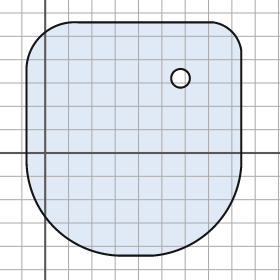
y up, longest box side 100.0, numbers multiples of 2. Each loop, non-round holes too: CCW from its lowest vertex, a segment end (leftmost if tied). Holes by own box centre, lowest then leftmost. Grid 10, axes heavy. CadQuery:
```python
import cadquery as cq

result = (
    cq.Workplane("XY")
    .moveTo(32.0, -44.0)
    .lineTo(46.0, -44.0)
    .threePointArc((72.0, -32.0), (84.0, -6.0))
    .lineTo(84.0, 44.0)
    .threePointArc((80.0, 52.0), (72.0, 56.0))
    .lineTo(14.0, 56.0)
    .threePointArc((-2.0, 50.0), (-8.0, 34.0))
    .lineTo(-8.0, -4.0)
    .threePointArc((4.0, -32.0), (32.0, -44.0))
    .close()
    .moveTo(58.0, 32.0)
    .circle(4.0)
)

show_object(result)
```